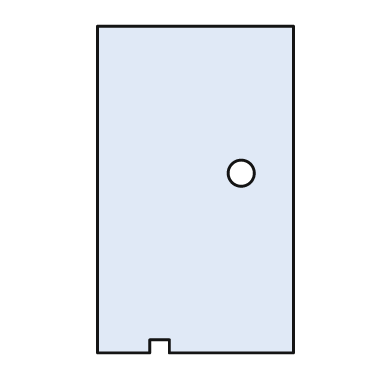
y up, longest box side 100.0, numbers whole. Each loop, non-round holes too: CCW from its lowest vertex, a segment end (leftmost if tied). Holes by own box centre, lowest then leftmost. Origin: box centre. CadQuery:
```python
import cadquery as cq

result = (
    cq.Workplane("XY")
    .moveTo(-30.0, -50.0)
    .lineTo(-14.0, -50.0)
    .lineTo(-14.0, -46.0)
    .lineTo(-8.0, -46.0)
    .lineTo(-8.0, -50.0)
    .lineTo(30.0, -50.0)
    .lineTo(30.0, 50.0)
    .lineTo(-30.0, 50.0)
    .close()
    .moveTo(14.0, 5.0)
    .circle(4.0)
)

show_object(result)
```